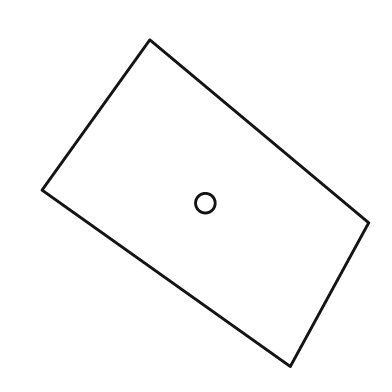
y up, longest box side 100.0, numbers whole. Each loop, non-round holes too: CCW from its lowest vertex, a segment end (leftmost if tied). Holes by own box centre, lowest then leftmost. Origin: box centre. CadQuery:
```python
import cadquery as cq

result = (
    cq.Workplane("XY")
    .moveTo(26.0, -50.0)
    .lineTo(50.0, -6.0)
    .lineTo(-17.0, 50.0)
    .lineTo(-50.0, 4.0)
    .close()
    .moveTo(0.0, 0.0)
    .circle(3.0)
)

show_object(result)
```